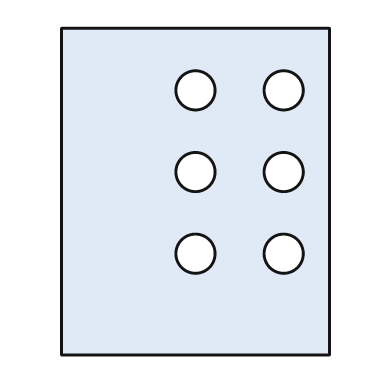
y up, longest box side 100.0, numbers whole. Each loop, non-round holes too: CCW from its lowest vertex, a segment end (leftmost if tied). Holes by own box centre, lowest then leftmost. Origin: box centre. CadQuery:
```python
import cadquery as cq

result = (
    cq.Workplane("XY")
    .moveTo(-41.0, -50.0)
    .lineTo(41.0, -50.0)
    .lineTo(41.0, 50.0)
    .lineTo(-41.0, 50.0)
    .close()
    .moveTo(0.0, -19.0)
    .circle(6.0)
    .moveTo(27.0, -19.0)
    .circle(6.0)
    .moveTo(0.0, 6.0)
    .circle(6.0)
    .moveTo(27.0, 6.0)
    .circle(6.0)
    .moveTo(0.0, 31.0)
    .circle(6.0)
    .moveTo(27.0, 31.0)
    .circle(6.0)
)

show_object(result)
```